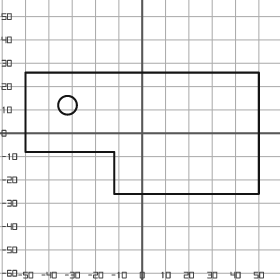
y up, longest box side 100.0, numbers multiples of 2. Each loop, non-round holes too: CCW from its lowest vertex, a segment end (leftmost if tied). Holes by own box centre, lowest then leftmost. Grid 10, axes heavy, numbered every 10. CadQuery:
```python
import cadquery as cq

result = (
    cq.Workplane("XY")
    .moveTo(-12.0, -26.0)
    .lineTo(50.0, -26.0)
    .lineTo(50.0, 26.0)
    .lineTo(-50.0, 26.0)
    .lineTo(-50.0, -8.0)
    .lineTo(-12.0, -8.0)
    .close()
    .moveTo(-32.0, 12.0)
    .circle(4.0)
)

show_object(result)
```